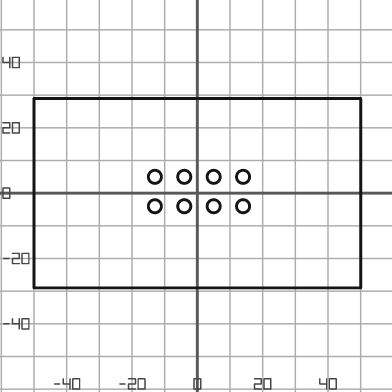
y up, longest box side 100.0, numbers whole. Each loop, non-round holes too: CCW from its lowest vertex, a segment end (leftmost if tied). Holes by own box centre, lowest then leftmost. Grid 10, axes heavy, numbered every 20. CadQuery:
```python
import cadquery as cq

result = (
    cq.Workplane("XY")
    .moveTo(-50.0, -29.0)
    .lineTo(50.0, -29.0)
    .lineTo(50.0, 29.0)
    .lineTo(-50.0, 29.0)
    .close()
    .moveTo(-13.0, -4.0)
    .circle(2.0)
    .moveTo(-4.0, -4.0)
    .circle(2.0)
    .moveTo(5.0, -4.0)
    .circle(2.0)
    .moveTo(14.0, -4.0)
    .circle(2.0)
    .moveTo(-13.0, 5.0)
    .circle(2.0)
    .moveTo(-4.0, 5.0)
    .circle(2.0)
    .moveTo(5.0, 5.0)
    .circle(2.0)
    .moveTo(14.0, 5.0)
    .circle(2.0)
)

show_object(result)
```